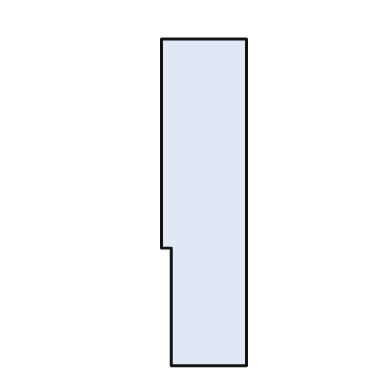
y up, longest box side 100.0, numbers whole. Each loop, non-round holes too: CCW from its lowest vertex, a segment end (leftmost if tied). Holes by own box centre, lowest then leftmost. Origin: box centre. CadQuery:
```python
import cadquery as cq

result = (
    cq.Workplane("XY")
    .moveTo(-10.0, -50.0)
    .lineTo(13.0, -50.0)
    .lineTo(13.0, 50.0)
    .lineTo(-13.0, 50.0)
    .lineTo(-13.0, -14.0)
    .lineTo(-10.0, -14.0)
    .close()
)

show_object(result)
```